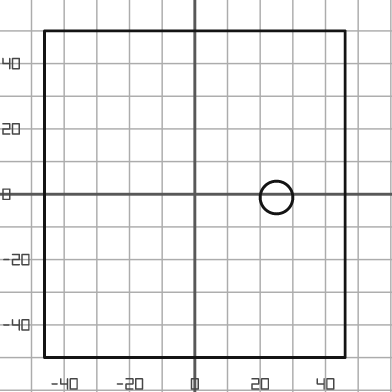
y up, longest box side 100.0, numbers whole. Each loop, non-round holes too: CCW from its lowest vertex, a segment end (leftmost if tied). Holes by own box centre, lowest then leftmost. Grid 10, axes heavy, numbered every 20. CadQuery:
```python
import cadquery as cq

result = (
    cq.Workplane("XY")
    .moveTo(-46.0, -50.0)
    .lineTo(46.0, -50.0)
    .lineTo(46.0, 50.0)
    .lineTo(-46.0, 50.0)
    .close()
    .moveTo(25.0, -1.0)
    .circle(5.0)
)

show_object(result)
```